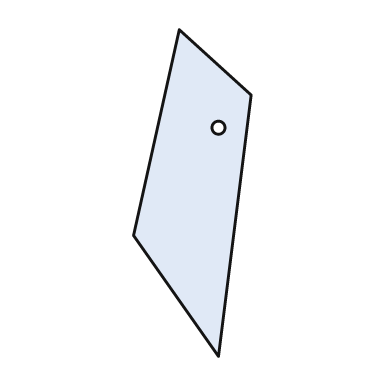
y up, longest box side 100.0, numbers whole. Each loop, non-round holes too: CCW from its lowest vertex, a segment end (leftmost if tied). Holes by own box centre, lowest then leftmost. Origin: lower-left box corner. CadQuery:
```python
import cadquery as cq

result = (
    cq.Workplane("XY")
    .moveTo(26.0, 0.0)
    .lineTo(36.0, 80.0)
    .lineTo(14.0, 100.0)
    .lineTo(0.0, 37.0)
    .close()
    .moveTo(26.0, 70.0)
    .circle(2.0)
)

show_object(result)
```